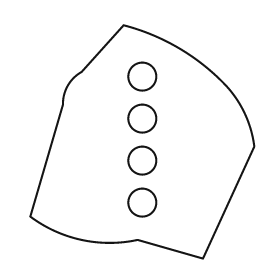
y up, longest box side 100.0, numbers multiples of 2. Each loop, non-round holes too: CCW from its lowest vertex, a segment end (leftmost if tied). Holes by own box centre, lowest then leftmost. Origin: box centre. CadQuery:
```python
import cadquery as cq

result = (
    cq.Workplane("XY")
    .moveTo(26.0, -50.0)
    .lineTo(48.0, -2.0)
    .threePointArc((44.0, 12.0), (36.0, 24.0))
    .threePointArc((16.0, 40.0), (-8.0, 50.0))
    .lineTo(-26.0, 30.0)
    .threePointArc((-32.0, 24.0), (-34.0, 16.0))
    .lineTo(-48.0, -32.0)
    .threePointArc((-26.0, -42.0), (-2.0, -42.0))
    .close()
    .moveTo(0.0, -26.0)
    .circle(6.0)
    .moveTo(0.0, -8.0)
    .circle(6.0)
    .moveTo(0.0, 10.0)
    .circle(6.0)
    .moveTo(0.0, 28.0)
    .circle(6.0)
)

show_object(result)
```